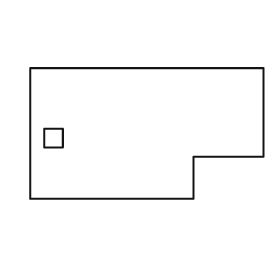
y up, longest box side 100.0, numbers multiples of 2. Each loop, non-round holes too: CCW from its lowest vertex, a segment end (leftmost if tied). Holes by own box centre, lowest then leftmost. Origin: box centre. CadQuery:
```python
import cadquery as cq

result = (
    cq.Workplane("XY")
    .moveTo(-50.0, -28.0)
    .lineTo(20.0, -28.0)
    .lineTo(20.0, -10.0)
    .lineTo(50.0, -10.0)
    .lineTo(50.0, 28.0)
    .lineTo(-50.0, 28.0)
    .close()
    .moveTo(-44.0, -6.0)
    .lineTo(-36.0, -6.0)
    .lineTo(-36.0, 2.0)
    .lineTo(-44.0, 2.0)
    .close()
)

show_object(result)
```